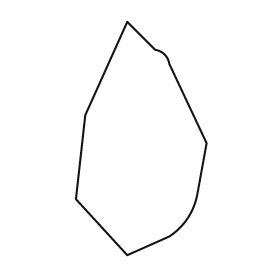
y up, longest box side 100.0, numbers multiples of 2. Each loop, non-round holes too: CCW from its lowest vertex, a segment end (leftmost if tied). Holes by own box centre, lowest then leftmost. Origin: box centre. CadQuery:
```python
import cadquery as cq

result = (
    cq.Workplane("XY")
    .moveTo(-6.0, -50.0)
    .lineTo(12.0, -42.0)
    .threePointArc((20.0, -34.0), (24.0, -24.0))
    .lineTo(28.0, -2.0)
    .lineTo(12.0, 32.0)
    .threePointArc((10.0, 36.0), (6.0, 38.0))
    .lineTo(-6.0, 50.0)
    .lineTo(-24.0, 10.0)
    .lineTo(-28.0, -26.0)
    .close()
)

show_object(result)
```